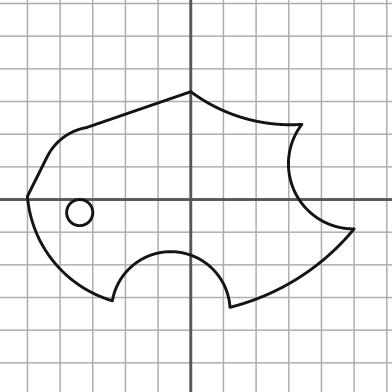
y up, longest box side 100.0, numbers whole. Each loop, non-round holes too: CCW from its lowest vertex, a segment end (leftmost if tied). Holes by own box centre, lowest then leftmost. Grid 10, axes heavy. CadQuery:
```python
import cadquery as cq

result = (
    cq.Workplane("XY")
    .moveTo(12.0, -33.0)
    .threePointArc((33.0, -24.0), (50.0, -9.0))
    .threePointArc((32.0, 2.0), (34.0, 23.0))
    .threePointArc((16.0, 25.0), (0.0, 33.0))
    .lineTo(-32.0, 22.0)
    .threePointArc((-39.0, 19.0), (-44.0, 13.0))
    .lineTo(-50.0, 1.0)
    .threePointArc((-42.0, -19.0), (-24.0, -31.0))
    .threePointArc((-5.0, -16.0), (12.0, -33.0))
    .close()
    .moveTo(-34.0, -4.0)
    .circle(4.0)
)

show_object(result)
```